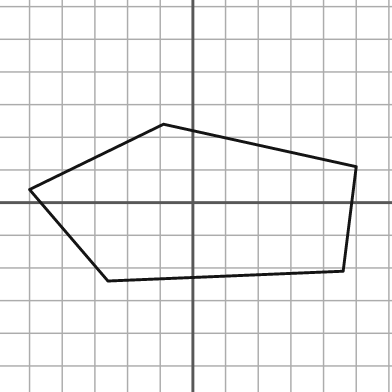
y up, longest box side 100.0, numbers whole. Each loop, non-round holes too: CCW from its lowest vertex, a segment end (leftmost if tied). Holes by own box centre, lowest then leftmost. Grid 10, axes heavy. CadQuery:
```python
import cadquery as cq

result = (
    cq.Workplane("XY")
    .moveTo(-26.0, -24.0)
    .lineTo(46.0, -21.0)
    .lineTo(50.0, 11.0)
    .lineTo(-9.0, 24.0)
    .lineTo(-50.0, 4.0)
    .close()
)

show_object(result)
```